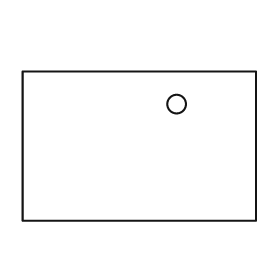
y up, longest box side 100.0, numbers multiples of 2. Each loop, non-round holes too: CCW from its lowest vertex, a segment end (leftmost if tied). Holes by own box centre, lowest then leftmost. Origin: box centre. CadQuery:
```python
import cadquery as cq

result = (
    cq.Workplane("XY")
    .moveTo(-50.0, -32.0)
    .lineTo(50.0, -32.0)
    .lineTo(50.0, 32.0)
    .lineTo(-50.0, 32.0)
    .close()
    .moveTo(16.0, 18.0)
    .circle(4.0)
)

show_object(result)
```